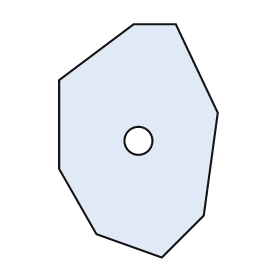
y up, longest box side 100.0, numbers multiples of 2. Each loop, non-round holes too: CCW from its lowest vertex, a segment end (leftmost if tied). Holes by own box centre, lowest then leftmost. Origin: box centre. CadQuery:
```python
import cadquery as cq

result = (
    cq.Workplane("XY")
    .moveTo(10.0, -50.0)
    .lineTo(28.0, -32.0)
    .lineTo(34.0, 12.0)
    .lineTo(16.0, 50.0)
    .lineTo(-2.0, 50.0)
    .lineTo(-34.0, 26.0)
    .lineTo(-34.0, -12.0)
    .lineTo(-18.0, -40.0)
    .close()
    .moveTo(0.0, 0.0)
    .circle(6.0)
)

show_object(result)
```